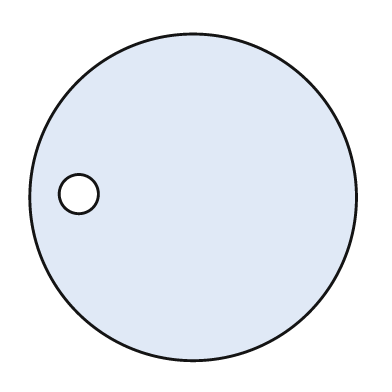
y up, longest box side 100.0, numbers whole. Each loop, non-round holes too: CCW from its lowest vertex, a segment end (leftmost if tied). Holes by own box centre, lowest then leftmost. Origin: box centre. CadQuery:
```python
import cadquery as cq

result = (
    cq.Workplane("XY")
    .moveTo(0.0, 0.0)
    .circle(50.0)
    .moveTo(-35.0, 1.0)
    .circle(6.0)
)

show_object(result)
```